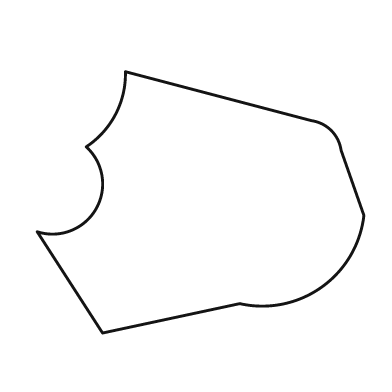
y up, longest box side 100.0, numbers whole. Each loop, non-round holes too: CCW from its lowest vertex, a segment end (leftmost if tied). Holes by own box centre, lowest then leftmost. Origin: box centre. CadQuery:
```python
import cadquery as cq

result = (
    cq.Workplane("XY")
    .moveTo(-30.0, -40.0)
    .lineTo(12.0, -31.0)
    .threePointArc((37.0, -26.0), (50.0, -4.0))
    .lineTo(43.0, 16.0)
    .threePointArc((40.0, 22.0), (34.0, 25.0))
    .lineTo(-23.0, 40.0)
    .threePointArc((-26.0, 27.0), (-35.0, 17.0))
    .threePointArc((-32.0, -2.0), (-50.0, -9.0))
    .close()
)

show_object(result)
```